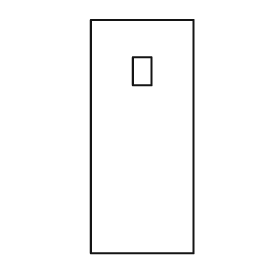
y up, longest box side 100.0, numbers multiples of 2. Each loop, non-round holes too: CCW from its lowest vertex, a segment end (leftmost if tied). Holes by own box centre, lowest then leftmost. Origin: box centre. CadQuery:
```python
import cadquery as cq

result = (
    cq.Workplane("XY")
    .moveTo(-22.0, -50.0)
    .lineTo(22.0, -50.0)
    .lineTo(22.0, 50.0)
    .lineTo(-22.0, 50.0)
    .close()
    .moveTo(-4.0, 22.0)
    .lineTo(4.0, 22.0)
    .lineTo(4.0, 34.0)
    .lineTo(-4.0, 34.0)
    .close()
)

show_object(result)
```